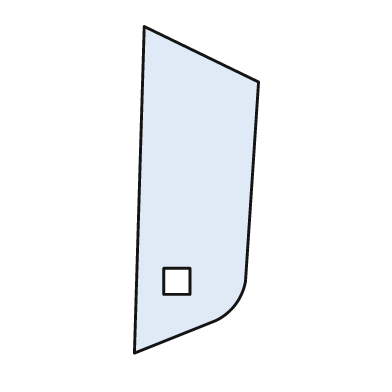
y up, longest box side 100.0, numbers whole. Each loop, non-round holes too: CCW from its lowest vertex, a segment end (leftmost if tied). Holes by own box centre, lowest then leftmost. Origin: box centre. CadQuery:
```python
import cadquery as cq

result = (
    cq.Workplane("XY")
    .moveTo(-19.0, -50.0)
    .lineTo(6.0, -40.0)
    .threePointArc((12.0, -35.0), (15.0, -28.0))
    .lineTo(19.0, 33.0)
    .lineTo(-16.0, 50.0)
    .close()
    .moveTo(-10.0, -32.0)
    .lineTo(-2.0, -32.0)
    .lineTo(-2.0, -24.0)
    .lineTo(-10.0, -24.0)
    .close()
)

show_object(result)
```